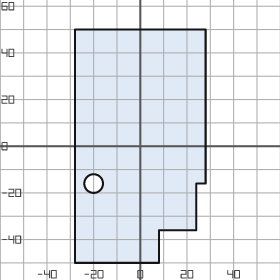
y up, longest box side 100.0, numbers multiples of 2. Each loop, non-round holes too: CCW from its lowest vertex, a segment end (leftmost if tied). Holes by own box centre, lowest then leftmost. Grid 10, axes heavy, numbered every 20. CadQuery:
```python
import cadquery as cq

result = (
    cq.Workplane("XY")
    .moveTo(-28.0, -50.0)
    .lineTo(8.0, -50.0)
    .lineTo(8.0, -36.0)
    .lineTo(24.0, -36.0)
    .lineTo(24.0, -16.0)
    .lineTo(28.0, -16.0)
    .lineTo(28.0, 50.0)
    .lineTo(-28.0, 50.0)
    .close()
    .moveTo(-20.0, -16.0)
    .circle(4.0)
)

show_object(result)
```